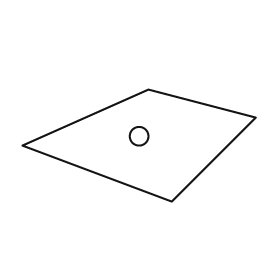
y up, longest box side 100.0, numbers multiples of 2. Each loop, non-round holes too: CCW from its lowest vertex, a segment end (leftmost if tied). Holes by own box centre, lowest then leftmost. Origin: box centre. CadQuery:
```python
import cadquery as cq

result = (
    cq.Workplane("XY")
    .moveTo(14.0, -24.0)
    .lineTo(50.0, 12.0)
    .lineTo(4.0, 24.0)
    .lineTo(-50.0, 0.0)
    .close()
    .moveTo(0.0, 4.0)
    .circle(4.0)
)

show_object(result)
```